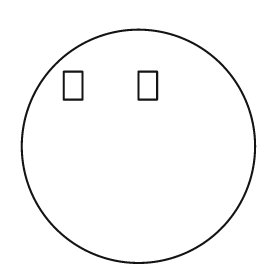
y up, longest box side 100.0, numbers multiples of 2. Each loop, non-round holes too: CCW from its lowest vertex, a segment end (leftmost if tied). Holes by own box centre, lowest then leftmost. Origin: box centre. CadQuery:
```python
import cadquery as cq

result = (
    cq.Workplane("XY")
    .moveTo(0.0, 0.0)
    .circle(50.0)
    .moveTo(-32.0, 20.0)
    .lineTo(-24.0, 20.0)
    .lineTo(-24.0, 32.0)
    .lineTo(-32.0, 32.0)
    .close()
    .moveTo(0.0, 20.0)
    .lineTo(8.0, 20.0)
    .lineTo(8.0, 32.0)
    .lineTo(0.0, 32.0)
    .close()
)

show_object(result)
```